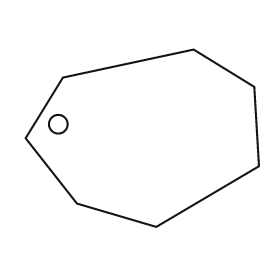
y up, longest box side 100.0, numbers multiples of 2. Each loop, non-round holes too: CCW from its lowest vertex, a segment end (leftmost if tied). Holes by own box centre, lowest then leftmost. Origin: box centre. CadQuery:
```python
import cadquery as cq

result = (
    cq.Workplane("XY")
    .moveTo(6.0, -38.0)
    .lineTo(50.0, -12.0)
    .lineTo(48.0, 22.0)
    .lineTo(22.0, 38.0)
    .lineTo(-34.0, 26.0)
    .lineTo(-50.0, 0.0)
    .lineTo(-28.0, -28.0)
    .close()
    .moveTo(-36.0, 6.0)
    .circle(4.0)
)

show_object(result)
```